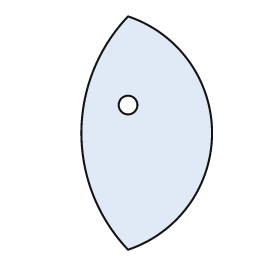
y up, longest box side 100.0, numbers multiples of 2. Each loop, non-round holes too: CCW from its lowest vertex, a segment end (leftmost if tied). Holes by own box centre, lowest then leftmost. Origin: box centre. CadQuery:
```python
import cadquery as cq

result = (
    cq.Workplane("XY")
    .moveTo(-8.0, -50.0)
    .threePointArc((28.0, 0.0), (-8.0, 50.0))
    .threePointArc((-28.0, 0.0), (-8.0, -50.0))
    .close()
    .moveTo(-8.0, 12.0)
    .circle(4.0)
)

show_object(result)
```